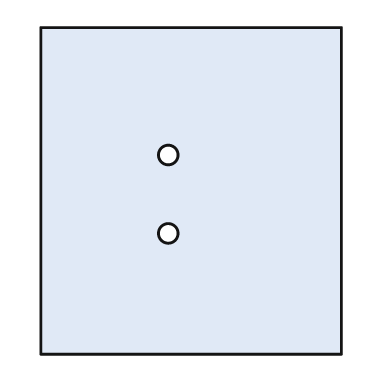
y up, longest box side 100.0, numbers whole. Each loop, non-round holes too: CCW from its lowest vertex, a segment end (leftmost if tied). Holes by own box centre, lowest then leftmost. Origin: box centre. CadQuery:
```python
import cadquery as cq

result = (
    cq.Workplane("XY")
    .moveTo(-46.0, -50.0)
    .lineTo(46.0, -50.0)
    .lineTo(46.0, 50.0)
    .lineTo(-46.0, 50.0)
    .close()
    .moveTo(-7.0, -13.0)
    .circle(3.0)
    .moveTo(-7.0, 11.0)
    .circle(3.0)
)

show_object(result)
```